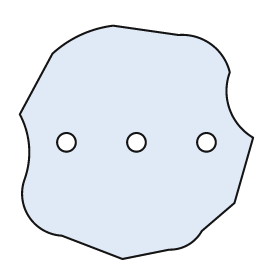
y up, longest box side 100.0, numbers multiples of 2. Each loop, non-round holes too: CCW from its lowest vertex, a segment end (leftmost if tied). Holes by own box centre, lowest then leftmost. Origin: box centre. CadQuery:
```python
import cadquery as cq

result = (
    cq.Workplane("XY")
    .moveTo(-6.0, -50.0)
    .lineTo(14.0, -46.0)
    .threePointArc((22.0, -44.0), (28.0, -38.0))
    .lineTo(42.0, -26.0)
    .lineTo(50.0, 2.0)
    .threePointArc((40.0, 14.0), (40.0, 30.0))
    .threePointArc((32.0, 42.0), (18.0, 46.0))
    .lineTo(-10.0, 50.0)
    .threePointArc((-24.0, 46.0), (-36.0, 38.0))
    .lineTo(-50.0, 12.0)
    .threePointArc((-46.0, -2.0), (-48.0, -16.0))
    .threePointArc((-46.0, -32.0), (-32.0, -40.0))
    .close()
    .moveTo(-30.0, 0.0)
    .circle(4.0)
    .moveTo(0.0, 0.0)
    .circle(4.0)
    .moveTo(30.0, 0.0)
    .circle(4.0)
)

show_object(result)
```